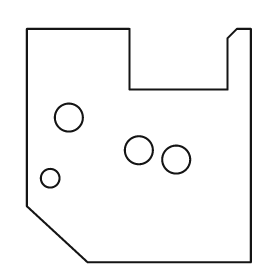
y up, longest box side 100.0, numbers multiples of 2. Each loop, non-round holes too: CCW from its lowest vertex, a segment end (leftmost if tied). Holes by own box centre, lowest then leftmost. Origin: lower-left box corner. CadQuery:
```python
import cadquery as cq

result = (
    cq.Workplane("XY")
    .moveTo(26.0, 0.0)
    .lineTo(96.0, 0.0)
    .lineTo(96.0, 100.0)
    .lineTo(90.0, 100.0)
    .lineTo(86.0, 96.0)
    .lineTo(86.0, 74.0)
    .lineTo(44.0, 74.0)
    .lineTo(44.0, 100.0)
    .lineTo(0.0, 100.0)
    .lineTo(0.0, 24.0)
    .close()
    .moveTo(10.0, 36.0)
    .circle(4.0)
    .moveTo(64.0, 44.0)
    .circle(6.0)
    .moveTo(48.0, 48.0)
    .circle(6.0)
    .moveTo(18.0, 62.0)
    .circle(6.0)
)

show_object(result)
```